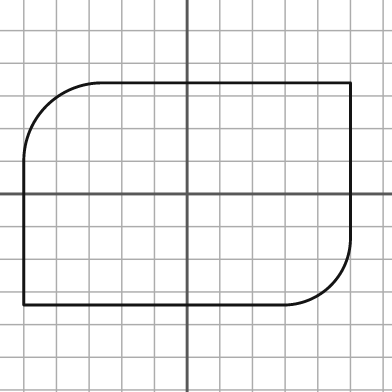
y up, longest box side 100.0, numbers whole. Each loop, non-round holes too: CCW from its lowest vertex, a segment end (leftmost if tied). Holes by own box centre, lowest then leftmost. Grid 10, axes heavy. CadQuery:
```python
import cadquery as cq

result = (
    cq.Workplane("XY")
    .moveTo(-50.0, -34.0)
    .lineTo(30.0, -34.0)
    .threePointArc((44.0, -28.0), (50.0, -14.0))
    .lineTo(50.0, 34.0)
    .lineTo(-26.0, 34.0)
    .threePointArc((-43.0, 27.0), (-50.0, 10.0))
    .close()
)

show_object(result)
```